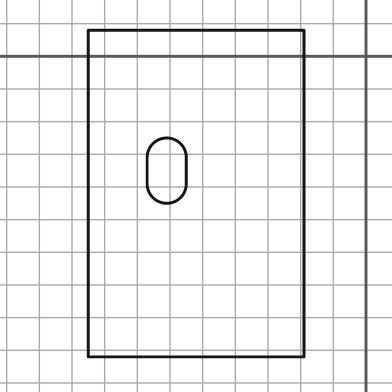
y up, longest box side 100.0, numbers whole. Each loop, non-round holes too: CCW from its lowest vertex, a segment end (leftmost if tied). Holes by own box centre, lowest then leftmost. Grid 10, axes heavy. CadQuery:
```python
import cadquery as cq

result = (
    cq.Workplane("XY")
    .moveTo(-85.0, -92.0)
    .lineTo(-19.0, -92.0)
    .lineTo(-19.0, 8.0)
    .lineTo(-85.0, 8.0)
    .close()
    .moveTo(-67.0, -39.0)
    .threePointArc((-61.0, -45.0), (-55.0, -39.0))
    .lineTo(-55.0, -31.0)
    .threePointArc((-61.0, -25.0), (-67.0, -31.0))
    .close()
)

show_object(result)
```